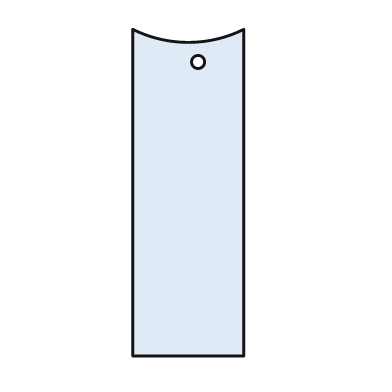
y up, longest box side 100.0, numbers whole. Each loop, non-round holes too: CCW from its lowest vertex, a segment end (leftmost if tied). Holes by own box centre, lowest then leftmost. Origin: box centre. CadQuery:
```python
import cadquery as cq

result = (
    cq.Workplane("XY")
    .moveTo(-17.0, -50.0)
    .lineTo(17.0, -50.0)
    .lineTo(17.0, 50.0)
    .threePointArc((0.0, 46.0), (-17.0, 50.0))
    .close()
    .moveTo(3.0, 40.0)
    .circle(2.0)
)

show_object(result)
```